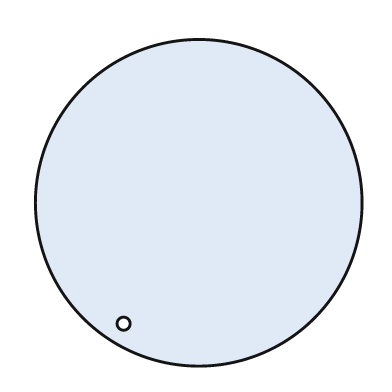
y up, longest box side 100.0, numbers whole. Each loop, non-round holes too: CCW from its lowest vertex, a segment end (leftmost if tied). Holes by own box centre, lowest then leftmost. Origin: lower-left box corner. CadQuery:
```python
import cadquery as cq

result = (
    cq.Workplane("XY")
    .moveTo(50.0, 50.0)
    .circle(50.0)
    .moveTo(27.0, 13.0)
    .circle(2.0)
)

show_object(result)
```